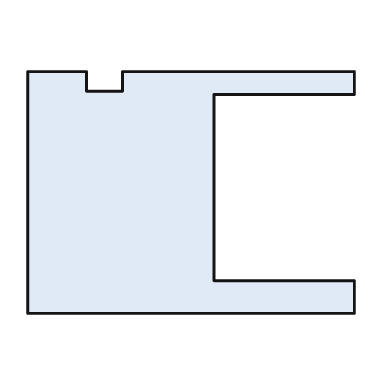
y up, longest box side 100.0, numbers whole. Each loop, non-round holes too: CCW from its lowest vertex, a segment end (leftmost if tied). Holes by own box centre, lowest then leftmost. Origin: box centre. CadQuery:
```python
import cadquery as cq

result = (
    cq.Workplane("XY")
    .moveTo(-50.0, -37.0)
    .lineTo(50.0, -37.0)
    .lineTo(50.0, -27.0)
    .lineTo(7.0, -27.0)
    .lineTo(7.0, 30.0)
    .lineTo(50.0, 30.0)
    .lineTo(50.0, 37.0)
    .lineTo(-21.0, 37.0)
    .lineTo(-21.0, 31.0)
    .lineTo(-32.0, 31.0)
    .lineTo(-32.0, 37.0)
    .lineTo(-50.0, 37.0)
    .close()
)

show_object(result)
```